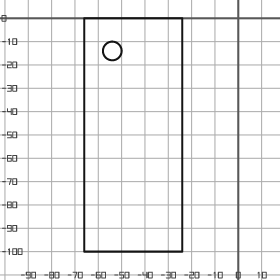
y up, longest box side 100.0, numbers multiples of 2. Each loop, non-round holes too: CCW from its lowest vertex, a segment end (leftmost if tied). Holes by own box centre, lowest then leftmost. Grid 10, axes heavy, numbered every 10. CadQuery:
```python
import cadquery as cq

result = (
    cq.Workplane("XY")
    .moveTo(-66.0, -100.0)
    .lineTo(-24.0, -100.0)
    .lineTo(-24.0, 0.0)
    .lineTo(-66.0, 0.0)
    .close()
    .moveTo(-54.0, -14.0)
    .circle(4.0)
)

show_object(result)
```